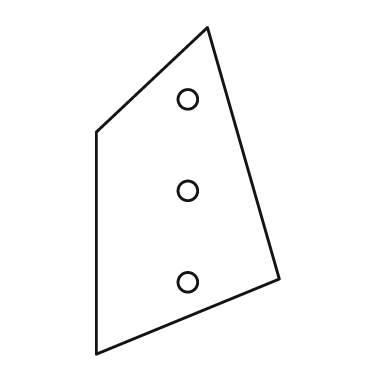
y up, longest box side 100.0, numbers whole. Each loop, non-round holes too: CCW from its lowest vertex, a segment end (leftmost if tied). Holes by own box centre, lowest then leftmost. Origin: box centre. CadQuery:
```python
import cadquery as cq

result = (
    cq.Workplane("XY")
    .moveTo(-28.0, -50.0)
    .lineTo(28.0, -27.0)
    .lineTo(6.0, 50.0)
    .lineTo(-28.0, 18.0)
    .close()
    .moveTo(0.0, -28.0)
    .circle(3.0)
    .moveTo(0.0, 0.0)
    .circle(3.0)
    .moveTo(0.0, 28.0)
    .circle(3.0)
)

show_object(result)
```